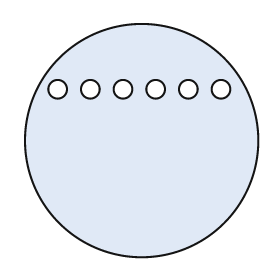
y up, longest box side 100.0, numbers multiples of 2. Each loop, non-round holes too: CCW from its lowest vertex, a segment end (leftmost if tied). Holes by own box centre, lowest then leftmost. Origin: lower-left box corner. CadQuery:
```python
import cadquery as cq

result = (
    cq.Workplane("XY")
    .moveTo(50.0, 50.0)
    .circle(50.0)
    .moveTo(14.0, 72.0)
    .circle(4.0)
    .moveTo(28.0, 72.0)
    .circle(4.0)
    .moveTo(42.0, 72.0)
    .circle(4.0)
    .moveTo(56.0, 72.0)
    .circle(4.0)
    .moveTo(70.0, 72.0)
    .circle(4.0)
    .moveTo(84.0, 72.0)
    .circle(4.0)
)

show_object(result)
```